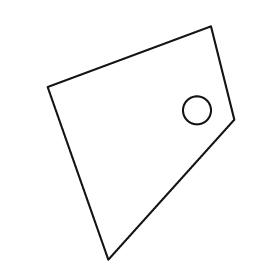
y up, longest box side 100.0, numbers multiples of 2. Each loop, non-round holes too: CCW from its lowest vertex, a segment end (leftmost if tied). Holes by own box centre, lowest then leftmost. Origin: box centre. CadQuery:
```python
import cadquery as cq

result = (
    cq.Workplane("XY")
    .moveTo(-14.0, -50.0)
    .lineTo(40.0, 10.0)
    .lineTo(30.0, 50.0)
    .lineTo(-40.0, 24.0)
    .close()
    .moveTo(24.0, 14.0)
    .circle(6.0)
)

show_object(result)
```